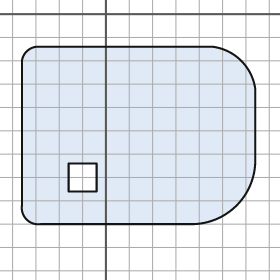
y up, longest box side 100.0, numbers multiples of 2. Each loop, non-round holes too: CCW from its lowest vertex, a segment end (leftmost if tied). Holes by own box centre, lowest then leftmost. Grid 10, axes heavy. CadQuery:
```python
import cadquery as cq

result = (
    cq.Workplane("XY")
    .moveTo(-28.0, -90.0)
    .lineTo(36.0, -90.0)
    .threePointArc((56.0, -82.0), (64.0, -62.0))
    .lineTo(64.0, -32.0)
    .threePointArc((58.0, -20.0), (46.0, -14.0))
    .lineTo(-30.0, -14.0)
    .threePointArc((-34.0, -16.0), (-36.0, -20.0))
    .lineTo(-36.0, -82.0)
    .threePointArc((-34.0, -88.0), (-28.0, -90.0))
    .close()
    .moveTo(-16.0, -76.0)
    .lineTo(-4.0, -76.0)
    .lineTo(-4.0, -64.0)
    .lineTo(-16.0, -64.0)
    .close()
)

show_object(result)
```